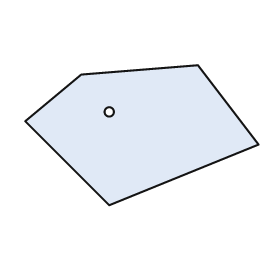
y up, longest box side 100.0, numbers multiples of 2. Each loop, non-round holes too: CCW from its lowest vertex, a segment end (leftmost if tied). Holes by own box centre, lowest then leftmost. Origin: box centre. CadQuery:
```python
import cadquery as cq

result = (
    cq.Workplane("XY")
    .moveTo(-14.0, -30.0)
    .lineTo(50.0, -4.0)
    .lineTo(24.0, 30.0)
    .lineTo(-26.0, 26.0)
    .lineTo(-50.0, 6.0)
    .close()
    .moveTo(-14.0, 10.0)
    .circle(2.0)
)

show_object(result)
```